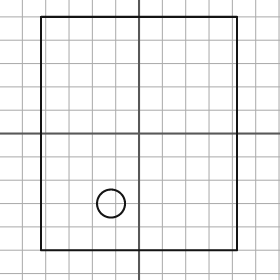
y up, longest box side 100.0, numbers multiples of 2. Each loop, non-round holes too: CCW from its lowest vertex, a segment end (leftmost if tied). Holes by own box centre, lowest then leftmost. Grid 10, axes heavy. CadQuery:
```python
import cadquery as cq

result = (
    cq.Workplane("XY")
    .moveTo(-42.0, -50.0)
    .lineTo(42.0, -50.0)
    .lineTo(42.0, 50.0)
    .lineTo(-42.0, 50.0)
    .close()
    .moveTo(-12.0, -30.0)
    .circle(6.0)
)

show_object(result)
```